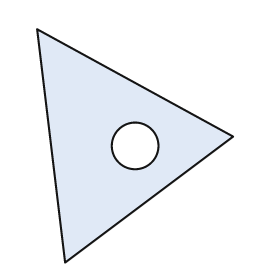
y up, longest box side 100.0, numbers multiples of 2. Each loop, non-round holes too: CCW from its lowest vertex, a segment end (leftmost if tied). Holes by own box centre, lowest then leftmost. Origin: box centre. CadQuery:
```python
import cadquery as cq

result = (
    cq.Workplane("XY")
    .moveTo(-30.0, -50.0)
    .lineTo(42.0, 4.0)
    .lineTo(-42.0, 50.0)
    .close()
    .moveTo(0.0, 0.0)
    .circle(10.0)
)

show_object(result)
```